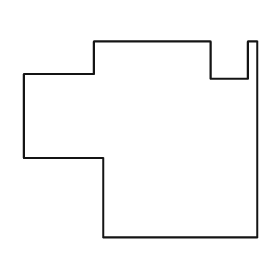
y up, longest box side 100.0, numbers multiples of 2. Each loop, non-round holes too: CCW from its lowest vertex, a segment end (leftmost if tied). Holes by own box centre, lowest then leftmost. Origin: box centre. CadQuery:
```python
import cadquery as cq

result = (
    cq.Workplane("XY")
    .moveTo(-16.0, -42.0)
    .lineTo(50.0, -42.0)
    .lineTo(50.0, 42.0)
    .lineTo(46.0, 42.0)
    .lineTo(46.0, 26.0)
    .lineTo(30.0, 26.0)
    .lineTo(30.0, 42.0)
    .lineTo(-20.0, 42.0)
    .lineTo(-20.0, 28.0)
    .lineTo(-50.0, 28.0)
    .lineTo(-50.0, -8.0)
    .lineTo(-16.0, -8.0)
    .close()
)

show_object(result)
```